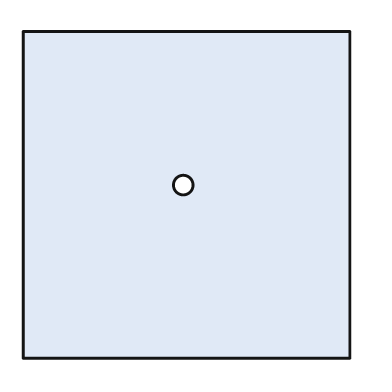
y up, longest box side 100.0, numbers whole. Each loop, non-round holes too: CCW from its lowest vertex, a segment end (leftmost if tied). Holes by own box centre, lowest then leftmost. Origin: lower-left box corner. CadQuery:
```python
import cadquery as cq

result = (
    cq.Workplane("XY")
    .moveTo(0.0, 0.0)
    .lineTo(100.0, 0.0)
    .lineTo(100.0, 100.0)
    .lineTo(0.0, 100.0)
    .close()
    .moveTo(49.0, 53.0)
    .circle(3.0)
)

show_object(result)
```